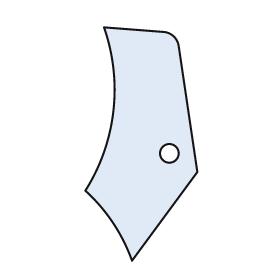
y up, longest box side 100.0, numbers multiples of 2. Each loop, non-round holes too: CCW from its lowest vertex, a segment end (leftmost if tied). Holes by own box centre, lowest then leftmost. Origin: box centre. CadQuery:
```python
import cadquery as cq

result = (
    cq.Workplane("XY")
    .moveTo(-4.0, -50.0)
    .lineTo(24.0, -12.0)
    .lineTo(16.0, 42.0)
    .threePointArc((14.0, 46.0), (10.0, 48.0))
    .lineTo(-16.0, 50.0)
    .threePointArc((-12.0, 14.0), (-24.0, -20.0))
    .threePointArc((-12.0, -34.0), (-4.0, -50.0))
    .close()
    .moveTo(12.0, -4.0)
    .circle(4.0)
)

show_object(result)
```